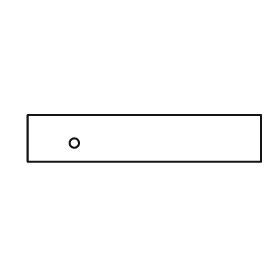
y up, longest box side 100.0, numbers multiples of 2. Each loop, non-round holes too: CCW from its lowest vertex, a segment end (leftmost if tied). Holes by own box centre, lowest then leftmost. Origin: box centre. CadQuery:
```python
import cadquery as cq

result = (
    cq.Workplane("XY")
    .moveTo(-50.0, -10.0)
    .lineTo(50.0, -10.0)
    .lineTo(50.0, 10.0)
    .lineTo(-50.0, 10.0)
    .close()
    .moveTo(-30.0, -2.0)
    .circle(2.0)
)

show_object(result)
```